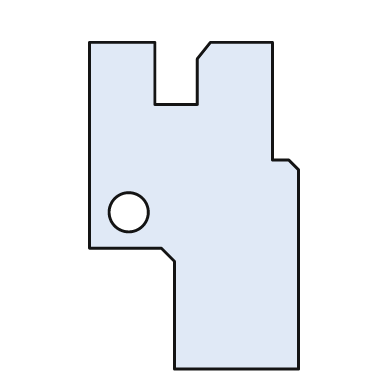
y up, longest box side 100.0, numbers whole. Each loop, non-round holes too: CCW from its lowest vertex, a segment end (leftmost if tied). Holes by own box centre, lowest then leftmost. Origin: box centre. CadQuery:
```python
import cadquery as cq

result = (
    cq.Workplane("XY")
    .moveTo(-6.0, -50.0)
    .lineTo(32.0, -50.0)
    .lineTo(32.0, 11.0)
    .lineTo(29.0, 14.0)
    .lineTo(24.0, 14.0)
    .lineTo(24.0, 50.0)
    .lineTo(5.0, 50.0)
    .lineTo(1.0, 45.0)
    .lineTo(1.0, 31.0)
    .lineTo(-12.0, 31.0)
    .lineTo(-12.0, 50.0)
    .lineTo(-32.0, 50.0)
    .lineTo(-32.0, -13.0)
    .lineTo(-10.0, -13.0)
    .lineTo(-6.0, -17.0)
    .close()
    .moveTo(-20.0, -2.0)
    .circle(6.0)
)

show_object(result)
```